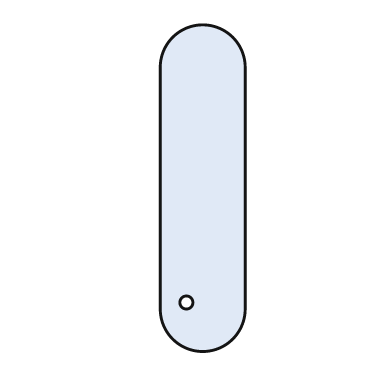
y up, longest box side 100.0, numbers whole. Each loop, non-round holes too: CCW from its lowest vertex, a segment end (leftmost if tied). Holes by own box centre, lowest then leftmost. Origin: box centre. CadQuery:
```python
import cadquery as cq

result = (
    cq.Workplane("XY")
    .moveTo(-13.0, -37.0)
    .threePointArc((0.0, -50.0), (13.0, -37.0))
    .lineTo(13.0, 37.0)
    .threePointArc((0.0, 50.0), (-13.0, 37.0))
    .close()
    .moveTo(-5.0, -35.0)
    .circle(2.0)
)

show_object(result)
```